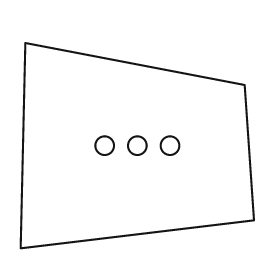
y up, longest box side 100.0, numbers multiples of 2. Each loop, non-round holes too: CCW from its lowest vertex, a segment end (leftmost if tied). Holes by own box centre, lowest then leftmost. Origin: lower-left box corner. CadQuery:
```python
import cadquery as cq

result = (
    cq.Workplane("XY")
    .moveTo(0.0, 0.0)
    .lineTo(100.0, 12.0)
    .lineTo(96.0, 70.0)
    .lineTo(2.0, 88.0)
    .close()
    .moveTo(36.0, 44.0)
    .circle(4.0)
    .moveTo(50.0, 44.0)
    .circle(4.0)
    .moveTo(64.0, 44.0)
    .circle(4.0)
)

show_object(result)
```